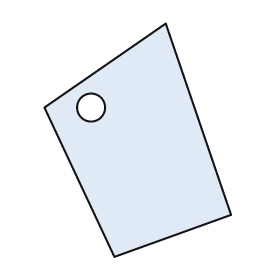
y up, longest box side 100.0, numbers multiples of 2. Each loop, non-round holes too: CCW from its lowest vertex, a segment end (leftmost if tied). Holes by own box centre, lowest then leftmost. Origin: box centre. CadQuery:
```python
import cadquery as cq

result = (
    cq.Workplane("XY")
    .moveTo(-10.0, -50.0)
    .lineTo(40.0, -32.0)
    .lineTo(12.0, 50.0)
    .lineTo(-40.0, 14.0)
    .close()
    .moveTo(-20.0, 14.0)
    .circle(6.0)
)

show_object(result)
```